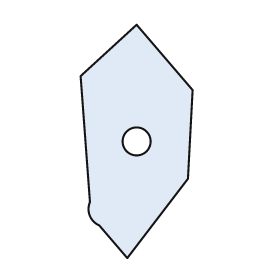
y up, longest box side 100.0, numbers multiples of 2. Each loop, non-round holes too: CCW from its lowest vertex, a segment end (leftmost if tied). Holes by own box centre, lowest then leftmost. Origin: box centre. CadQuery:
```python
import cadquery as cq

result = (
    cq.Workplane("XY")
    .moveTo(-4.0, -50.0)
    .lineTo(22.0, -16.0)
    .lineTo(24.0, 22.0)
    .lineTo(0.0, 50.0)
    .lineTo(-24.0, 28.0)
    .lineTo(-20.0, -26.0)
    .threePointArc((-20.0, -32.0), (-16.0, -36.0))
    .close()
    .moveTo(0.0, 0.0)
    .circle(6.0)
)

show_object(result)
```